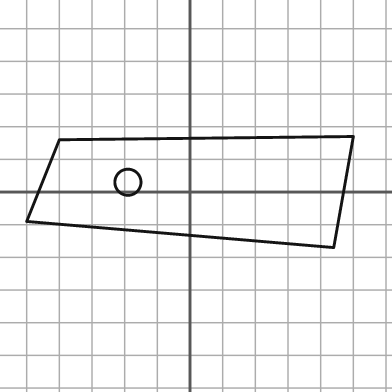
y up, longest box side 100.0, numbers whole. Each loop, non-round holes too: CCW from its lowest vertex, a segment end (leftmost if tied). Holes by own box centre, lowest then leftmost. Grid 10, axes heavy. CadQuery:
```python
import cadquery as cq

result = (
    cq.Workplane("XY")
    .moveTo(44.0, -17.0)
    .lineTo(50.0, 17.0)
    .lineTo(-40.0, 16.0)
    .lineTo(-50.0, -9.0)
    .close()
    .moveTo(-19.0, 3.0)
    .circle(4.0)
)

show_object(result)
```